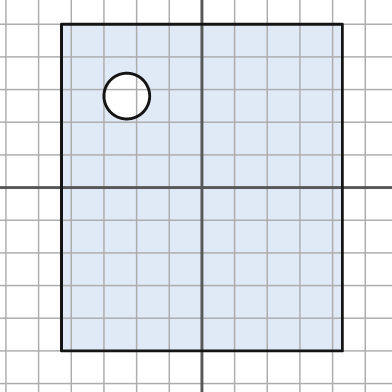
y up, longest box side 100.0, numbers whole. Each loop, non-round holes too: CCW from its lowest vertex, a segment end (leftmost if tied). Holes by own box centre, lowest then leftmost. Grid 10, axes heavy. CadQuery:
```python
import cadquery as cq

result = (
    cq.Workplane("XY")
    .moveTo(-43.0, -50.0)
    .lineTo(43.0, -50.0)
    .lineTo(43.0, 50.0)
    .lineTo(-43.0, 50.0)
    .close()
    .moveTo(-23.0, 28.0)
    .circle(7.0)
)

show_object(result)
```